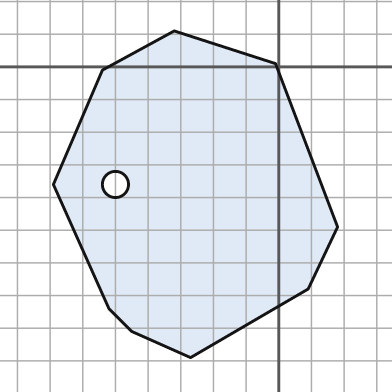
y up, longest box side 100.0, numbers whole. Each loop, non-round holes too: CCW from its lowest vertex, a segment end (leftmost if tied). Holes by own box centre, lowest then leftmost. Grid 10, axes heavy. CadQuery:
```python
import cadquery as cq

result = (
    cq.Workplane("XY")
    .moveTo(-27.0, -89.0)
    .lineTo(9.0, -68.0)
    .lineTo(18.0, -49.0)
    .lineTo(-1.0, 1.0)
    .lineTo(-32.0, 11.0)
    .lineTo(-54.0, -1.0)
    .lineTo(-69.0, -36.0)
    .lineTo(-52.0, -74.0)
    .lineTo(-45.0, -81.0)
    .close()
    .moveTo(-50.0, -36.0)
    .circle(4.0)
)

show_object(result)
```